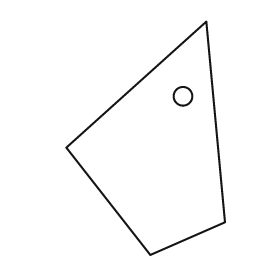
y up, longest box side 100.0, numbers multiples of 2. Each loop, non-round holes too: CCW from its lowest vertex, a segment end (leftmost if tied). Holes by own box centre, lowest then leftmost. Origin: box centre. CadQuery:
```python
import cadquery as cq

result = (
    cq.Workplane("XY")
    .moveTo(2.0, -50.0)
    .lineTo(34.0, -36.0)
    .lineTo(26.0, 50.0)
    .lineTo(-34.0, -4.0)
    .close()
    .moveTo(16.0, 18.0)
    .circle(4.0)
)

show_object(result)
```